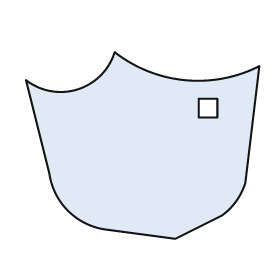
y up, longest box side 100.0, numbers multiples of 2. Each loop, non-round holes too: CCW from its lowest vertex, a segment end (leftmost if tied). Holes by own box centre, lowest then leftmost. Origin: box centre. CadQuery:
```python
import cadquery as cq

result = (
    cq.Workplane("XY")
    .moveTo(14.0, -40.0)
    .lineTo(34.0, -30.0)
    .threePointArc((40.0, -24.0), (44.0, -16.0))
    .lineTo(50.0, 34.0)
    .threePointArc((18.0, 28.0), (-12.0, 40.0))
    .threePointArc((-28.0, 24.0), (-50.0, 28.0))
    .lineTo(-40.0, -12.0)
    .threePointArc((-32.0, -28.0), (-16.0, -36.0))
    .close()
    .moveTo(24.0, 12.0)
    .lineTo(32.0, 12.0)
    .lineTo(32.0, 20.0)
    .lineTo(24.0, 20.0)
    .close()
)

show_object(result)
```